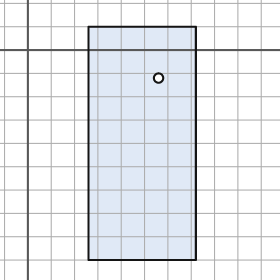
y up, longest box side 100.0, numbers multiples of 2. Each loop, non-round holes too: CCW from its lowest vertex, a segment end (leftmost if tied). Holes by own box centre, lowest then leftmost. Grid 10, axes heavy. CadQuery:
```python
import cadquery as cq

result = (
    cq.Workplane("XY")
    .moveTo(26.0, -90.0)
    .lineTo(72.0, -90.0)
    .lineTo(72.0, 10.0)
    .lineTo(26.0, 10.0)
    .close()
    .moveTo(56.0, -12.0)
    .circle(2.0)
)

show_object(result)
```